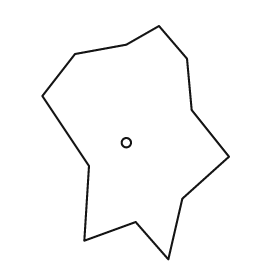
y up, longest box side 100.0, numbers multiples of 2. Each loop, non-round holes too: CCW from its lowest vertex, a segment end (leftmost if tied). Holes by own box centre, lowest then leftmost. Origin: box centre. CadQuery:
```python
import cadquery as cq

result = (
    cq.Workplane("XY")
    .moveTo(14.0, -50.0)
    .lineTo(20.0, -24.0)
    .lineTo(40.0, -6.0)
    .lineTo(24.0, 14.0)
    .lineTo(22.0, 36.0)
    .lineTo(10.0, 50.0)
    .lineTo(-4.0, 42.0)
    .lineTo(-26.0, 38.0)
    .lineTo(-40.0, 20.0)
    .lineTo(-20.0, -10.0)
    .lineTo(-22.0, -42.0)
    .lineTo(0.0, -34.0)
    .close()
    .moveTo(-4.0, 0.0)
    .circle(2.0)
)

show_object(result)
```